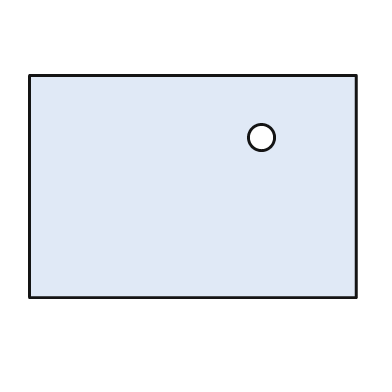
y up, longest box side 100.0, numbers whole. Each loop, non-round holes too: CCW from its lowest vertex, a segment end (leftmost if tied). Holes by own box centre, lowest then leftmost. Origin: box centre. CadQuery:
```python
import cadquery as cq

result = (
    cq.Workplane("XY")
    .moveTo(-50.0, -34.0)
    .lineTo(50.0, -34.0)
    .lineTo(50.0, 34.0)
    .lineTo(-50.0, 34.0)
    .close()
    .moveTo(21.0, 15.0)
    .circle(4.0)
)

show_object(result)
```